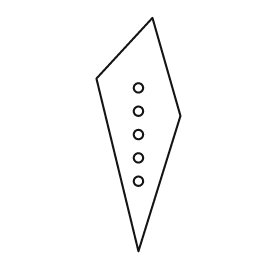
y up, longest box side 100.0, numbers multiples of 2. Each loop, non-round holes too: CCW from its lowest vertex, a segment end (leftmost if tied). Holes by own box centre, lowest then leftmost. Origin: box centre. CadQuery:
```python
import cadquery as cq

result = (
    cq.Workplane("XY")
    .moveTo(0.0, -50.0)
    .lineTo(18.0, 8.0)
    .lineTo(6.0, 50.0)
    .lineTo(-18.0, 24.0)
    .close()
    .moveTo(0.0, -20.0)
    .circle(2.0)
    .moveTo(0.0, -10.0)
    .circle(2.0)
    .moveTo(0.0, 0.0)
    .circle(2.0)
    .moveTo(0.0, 10.0)
    .circle(2.0)
    .moveTo(0.0, 20.0)
    .circle(2.0)
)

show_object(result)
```